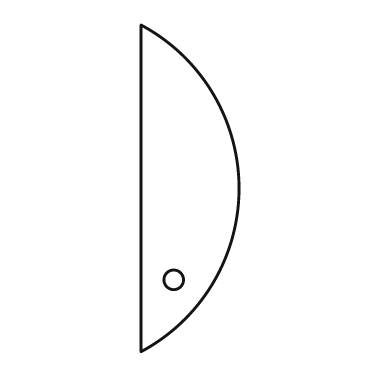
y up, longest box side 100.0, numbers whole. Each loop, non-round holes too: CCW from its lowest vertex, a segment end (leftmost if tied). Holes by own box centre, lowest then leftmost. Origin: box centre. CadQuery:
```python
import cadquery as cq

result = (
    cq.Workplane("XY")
    .moveTo(-15.0, -50.0)
    .threePointArc((15.0, 0.0), (-15.0, 50.0))
    .close()
    .moveTo(-5.0, -28.0)
    .circle(3.0)
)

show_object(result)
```